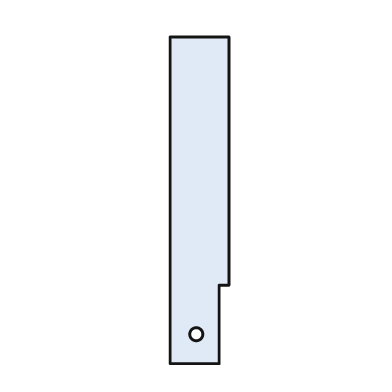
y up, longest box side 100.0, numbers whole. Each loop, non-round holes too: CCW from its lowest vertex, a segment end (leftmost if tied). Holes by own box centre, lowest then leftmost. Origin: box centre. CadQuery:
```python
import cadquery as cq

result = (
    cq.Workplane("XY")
    .moveTo(-9.0, -50.0)
    .lineTo(6.0, -50.0)
    .lineTo(6.0, -26.0)
    .lineTo(9.0, -26.0)
    .lineTo(9.0, 50.0)
    .lineTo(-9.0, 50.0)
    .close()
    .moveTo(-1.0, -41.0)
    .circle(2.0)
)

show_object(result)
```